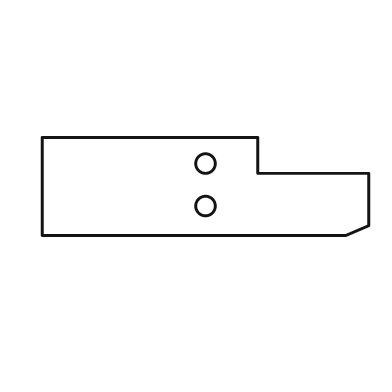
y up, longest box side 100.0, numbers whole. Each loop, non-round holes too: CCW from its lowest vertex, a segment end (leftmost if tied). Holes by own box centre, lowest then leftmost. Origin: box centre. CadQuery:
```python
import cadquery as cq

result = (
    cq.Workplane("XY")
    .moveTo(-50.0, -15.0)
    .lineTo(43.0, -15.0)
    .lineTo(50.0, -12.0)
    .lineTo(50.0, 4.0)
    .lineTo(16.0, 4.0)
    .lineTo(16.0, 15.0)
    .lineTo(-50.0, 15.0)
    .close()
    .moveTo(0.0, -6.0)
    .circle(3.0)
    .moveTo(0.0, 7.0)
    .circle(3.0)
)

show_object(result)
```